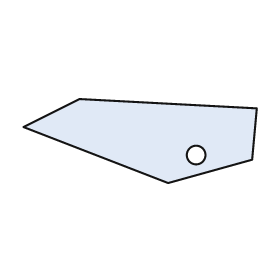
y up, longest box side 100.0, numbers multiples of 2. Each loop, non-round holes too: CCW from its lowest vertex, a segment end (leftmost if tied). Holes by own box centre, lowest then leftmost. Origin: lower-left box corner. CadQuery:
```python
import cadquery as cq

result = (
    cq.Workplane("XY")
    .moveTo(62.0, 0.0)
    .lineTo(98.0, 10.0)
    .lineTo(100.0, 32.0)
    .lineTo(24.0, 36.0)
    .lineTo(0.0, 24.0)
    .close()
    .moveTo(74.0, 12.0)
    .circle(4.0)
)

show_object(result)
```